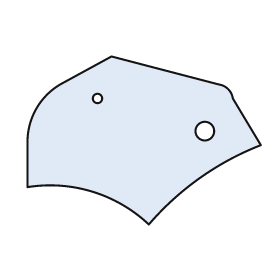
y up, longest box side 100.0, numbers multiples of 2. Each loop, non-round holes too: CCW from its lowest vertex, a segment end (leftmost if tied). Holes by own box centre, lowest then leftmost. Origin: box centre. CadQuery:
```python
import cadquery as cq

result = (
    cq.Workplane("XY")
    .moveTo(2.0, -36.0)
    .threePointArc((24.0, -16.0), (50.0, -2.0))
    .lineTo(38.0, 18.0)
    .threePointArc((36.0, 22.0), (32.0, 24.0))
    .lineTo(-14.0, 36.0)
    .lineTo(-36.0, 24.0)
    .threePointArc((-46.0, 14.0), (-50.0, 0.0))
    .lineTo(-50.0, -20.0)
    .threePointArc((-22.0, -22.0), (2.0, -36.0))
    .close()
    .moveTo(26.0, 4.0)
    .circle(4.0)
    .moveTo(-20.0, 18.0)
    .circle(2.0)
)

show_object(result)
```